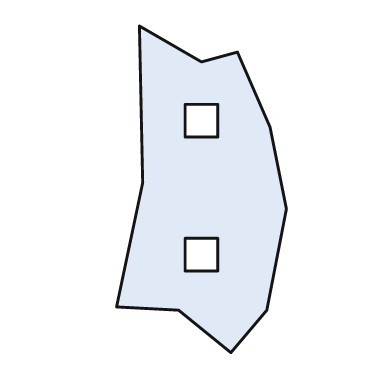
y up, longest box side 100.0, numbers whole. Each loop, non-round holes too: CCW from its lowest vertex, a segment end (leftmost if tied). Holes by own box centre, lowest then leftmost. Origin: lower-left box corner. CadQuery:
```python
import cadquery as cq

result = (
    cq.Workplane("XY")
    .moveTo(35.0, 0.0)
    .lineTo(46.0, 13.0)
    .lineTo(52.0, 44.0)
    .lineTo(47.0, 69.0)
    .lineTo(37.0, 92.0)
    .lineTo(26.0, 89.0)
    .lineTo(7.0, 100.0)
    .lineTo(8.0, 52.0)
    .lineTo(0.0, 14.0)
    .lineTo(19.0, 13.0)
    .close()
    .moveTo(21.0, 25.0)
    .lineTo(31.0, 25.0)
    .lineTo(31.0, 35.0)
    .lineTo(21.0, 35.0)
    .close()
    .moveTo(21.0, 66.0)
    .lineTo(31.0, 66.0)
    .lineTo(31.0, 76.0)
    .lineTo(21.0, 76.0)
    .close()
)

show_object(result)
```